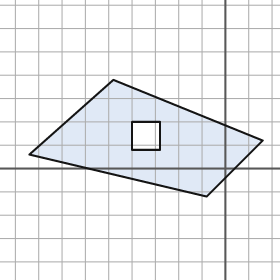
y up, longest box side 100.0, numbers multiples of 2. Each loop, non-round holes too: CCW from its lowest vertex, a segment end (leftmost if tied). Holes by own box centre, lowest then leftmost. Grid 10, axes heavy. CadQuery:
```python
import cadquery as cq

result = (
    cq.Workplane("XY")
    .moveTo(-8.0, -12.0)
    .lineTo(16.0, 12.0)
    .lineTo(-48.0, 38.0)
    .lineTo(-84.0, 6.0)
    .close()
    .moveTo(-40.0, 8.0)
    .lineTo(-28.0, 8.0)
    .lineTo(-28.0, 20.0)
    .lineTo(-40.0, 20.0)
    .close()
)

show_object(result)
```